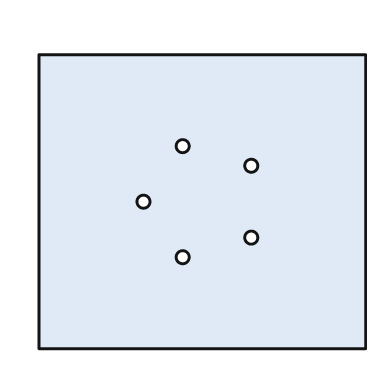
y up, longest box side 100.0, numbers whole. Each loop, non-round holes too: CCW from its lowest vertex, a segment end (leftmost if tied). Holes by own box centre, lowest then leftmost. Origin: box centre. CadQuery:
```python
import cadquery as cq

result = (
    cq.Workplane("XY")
    .moveTo(-50.0, -45.0)
    .lineTo(50.0, -45.0)
    .lineTo(50.0, 45.0)
    .lineTo(-50.0, 45.0)
    .close()
    .moveTo(-6.0, -17.0)
    .circle(2.0)
    .moveTo(15.0, -11.0)
    .circle(2.0)
    .moveTo(-18.0, 0.0)
    .circle(2.0)
    .moveTo(15.0, 11.0)
    .circle(2.0)
    .moveTo(-6.0, 17.0)
    .circle(2.0)
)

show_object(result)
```